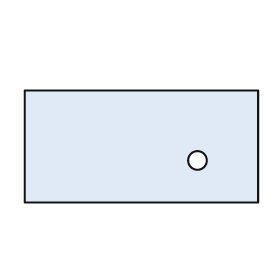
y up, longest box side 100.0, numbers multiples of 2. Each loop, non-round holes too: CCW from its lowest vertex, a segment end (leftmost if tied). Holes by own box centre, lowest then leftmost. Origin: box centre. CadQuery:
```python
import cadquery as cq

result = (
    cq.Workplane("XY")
    .moveTo(-50.0, -24.0)
    .lineTo(50.0, -24.0)
    .lineTo(50.0, 24.0)
    .lineTo(-50.0, 24.0)
    .close()
    .moveTo(24.0, -6.0)
    .circle(4.0)
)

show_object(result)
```